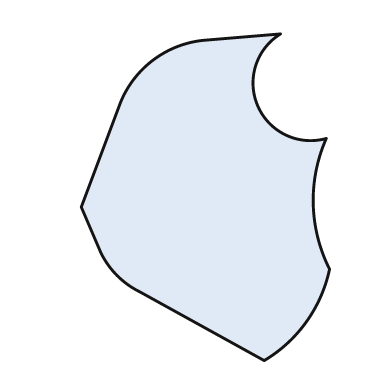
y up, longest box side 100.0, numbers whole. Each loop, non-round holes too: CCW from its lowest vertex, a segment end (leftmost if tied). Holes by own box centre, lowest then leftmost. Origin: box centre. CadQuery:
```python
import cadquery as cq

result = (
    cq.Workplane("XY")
    .moveTo(18.0, -50.0)
    .threePointArc((31.0, -38.0), (38.0, -22.0))
    .threePointArc((33.0, -2.0), (37.0, 18.0))
    .threePointArc((16.0, 28.0), (23.0, 50.0))
    .lineTo(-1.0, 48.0)
    .threePointArc((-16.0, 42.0), (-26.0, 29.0))
    .lineTo(-38.0, -3.0)
    .lineTo(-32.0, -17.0)
    .threePointArc((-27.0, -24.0), (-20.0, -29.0))
    .close()
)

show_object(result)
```